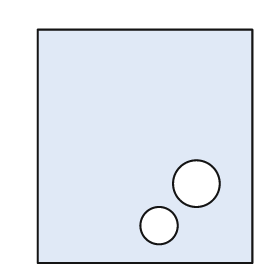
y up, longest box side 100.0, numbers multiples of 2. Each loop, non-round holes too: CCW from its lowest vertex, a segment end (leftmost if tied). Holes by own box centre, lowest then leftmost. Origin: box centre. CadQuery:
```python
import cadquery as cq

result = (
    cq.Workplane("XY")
    .moveTo(-46.0, -50.0)
    .lineTo(46.0, -50.0)
    .lineTo(46.0, 50.0)
    .lineTo(-46.0, 50.0)
    .close()
    .moveTo(6.0, -34.0)
    .circle(8.0)
    .moveTo(22.0, -16.0)
    .circle(10.0)
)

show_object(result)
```